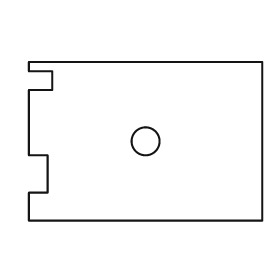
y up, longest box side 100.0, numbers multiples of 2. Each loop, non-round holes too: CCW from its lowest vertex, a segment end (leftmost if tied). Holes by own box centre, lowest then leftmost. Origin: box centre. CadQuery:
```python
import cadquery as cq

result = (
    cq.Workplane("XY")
    .moveTo(-50.0, -34.0)
    .lineTo(50.0, -34.0)
    .lineTo(50.0, 34.0)
    .lineTo(-50.0, 34.0)
    .lineTo(-50.0, 30.0)
    .lineTo(-40.0, 30.0)
    .lineTo(-40.0, 22.0)
    .lineTo(-50.0, 22.0)
    .lineTo(-50.0, -6.0)
    .lineTo(-42.0, -6.0)
    .lineTo(-42.0, -22.0)
    .lineTo(-50.0, -22.0)
    .close()
    .moveTo(0.0, 0.0)
    .circle(6.0)
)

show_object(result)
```